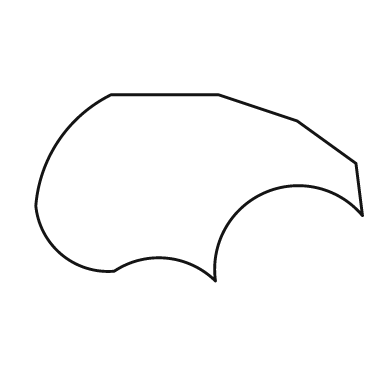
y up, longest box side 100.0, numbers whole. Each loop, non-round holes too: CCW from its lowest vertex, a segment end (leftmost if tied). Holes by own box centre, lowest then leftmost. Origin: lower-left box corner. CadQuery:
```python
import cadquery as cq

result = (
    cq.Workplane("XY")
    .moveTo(55.0, 0.0)
    .threePointArc((70.0, 27.0), (100.0, 20.0))
    .lineTo(98.0, 36.0)
    .lineTo(80.0, 49.0)
    .lineTo(56.0, 57.0)
    .lineTo(23.0, 57.0)
    .threePointArc((7.0, 43.0), (0.0, 23.0))
    .threePointArc((8.0, 8.0), (24.0, 3.0))
    .threePointArc((40.0, 7.0), (55.0, 0.0))
    .close()
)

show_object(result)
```